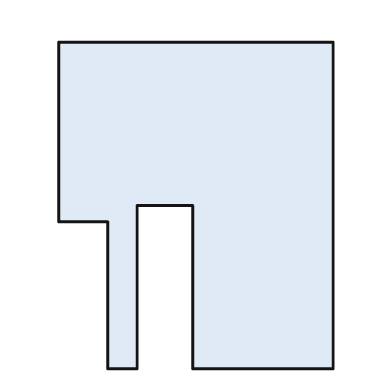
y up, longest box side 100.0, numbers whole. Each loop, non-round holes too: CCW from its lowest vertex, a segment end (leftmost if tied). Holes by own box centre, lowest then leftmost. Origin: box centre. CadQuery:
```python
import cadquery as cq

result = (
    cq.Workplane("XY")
    .moveTo(-27.0, -50.0)
    .lineTo(-18.0, -50.0)
    .lineTo(-18.0, 0.0)
    .lineTo(-1.0, 0.0)
    .lineTo(-1.0, -50.0)
    .lineTo(42.0, -50.0)
    .lineTo(42.0, 50.0)
    .lineTo(-42.0, 50.0)
    .lineTo(-42.0, -5.0)
    .lineTo(-27.0, -5.0)
    .close()
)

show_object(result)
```